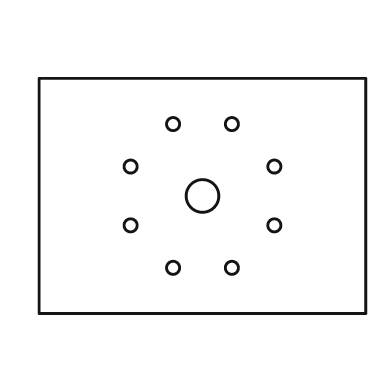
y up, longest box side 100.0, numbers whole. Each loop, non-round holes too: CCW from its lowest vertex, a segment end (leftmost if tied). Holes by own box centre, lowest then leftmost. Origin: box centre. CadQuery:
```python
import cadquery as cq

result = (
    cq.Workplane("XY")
    .moveTo(-50.0, -36.0)
    .lineTo(50.0, -36.0)
    .lineTo(50.0, 36.0)
    .lineTo(-50.0, 36.0)
    .close()
    .moveTo(-9.0, -22.0)
    .circle(2.0)
    .moveTo(9.0, -22.0)
    .circle(2.0)
    .moveTo(-22.0, -9.0)
    .circle(2.0)
    .moveTo(22.0, -9.0)
    .circle(2.0)
    .moveTo(0.0, 0.0)
    .circle(5.0)
    .moveTo(-22.0, 9.0)
    .circle(2.0)
    .moveTo(22.0, 9.0)
    .circle(2.0)
    .moveTo(-9.0, 22.0)
    .circle(2.0)
    .moveTo(9.0, 22.0)
    .circle(2.0)
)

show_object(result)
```